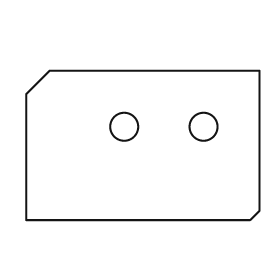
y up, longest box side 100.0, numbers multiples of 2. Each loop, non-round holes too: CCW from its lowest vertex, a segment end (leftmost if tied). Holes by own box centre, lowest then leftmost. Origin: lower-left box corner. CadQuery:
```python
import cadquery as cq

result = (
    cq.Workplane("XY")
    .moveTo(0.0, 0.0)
    .lineTo(96.0, 0.0)
    .lineTo(100.0, 4.0)
    .lineTo(100.0, 64.0)
    .lineTo(10.0, 64.0)
    .lineTo(0.0, 54.0)
    .close()
    .moveTo(42.0, 40.0)
    .circle(6.0)
    .moveTo(76.0, 40.0)
    .circle(6.0)
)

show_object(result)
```